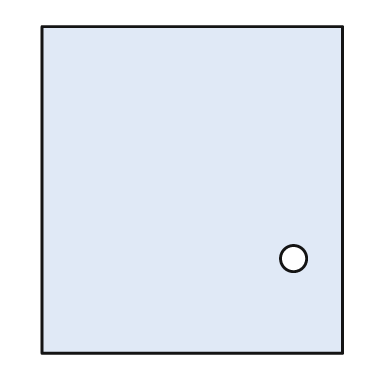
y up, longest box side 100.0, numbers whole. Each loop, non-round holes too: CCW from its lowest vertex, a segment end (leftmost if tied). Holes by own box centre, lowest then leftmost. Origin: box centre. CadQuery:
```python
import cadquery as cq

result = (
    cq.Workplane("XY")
    .moveTo(-46.0, -50.0)
    .lineTo(46.0, -50.0)
    .lineTo(46.0, 50.0)
    .lineTo(-46.0, 50.0)
    .close()
    .moveTo(31.0, -21.0)
    .circle(4.0)
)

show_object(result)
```